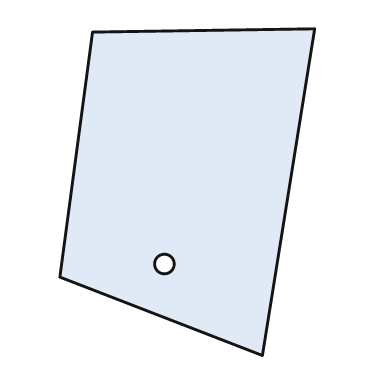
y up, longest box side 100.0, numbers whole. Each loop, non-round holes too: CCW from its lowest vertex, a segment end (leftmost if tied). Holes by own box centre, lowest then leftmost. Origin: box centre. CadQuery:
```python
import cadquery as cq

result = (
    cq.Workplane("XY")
    .moveTo(23.0, -50.0)
    .lineTo(39.0, 50.0)
    .lineTo(-29.0, 49.0)
    .lineTo(-39.0, -26.0)
    .close()
    .moveTo(-7.0, -22.0)
    .circle(3.0)
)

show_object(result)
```